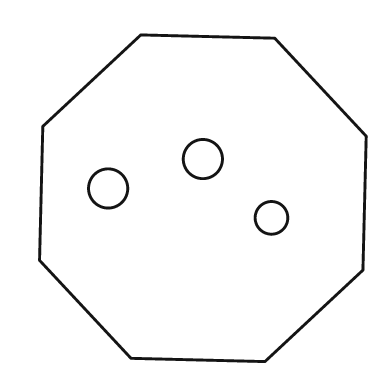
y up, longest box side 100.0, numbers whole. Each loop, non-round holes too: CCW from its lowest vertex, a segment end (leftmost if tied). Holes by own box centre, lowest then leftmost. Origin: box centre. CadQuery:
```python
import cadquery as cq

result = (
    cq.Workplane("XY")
    .moveTo(19.0, -50.0)
    .lineTo(49.0, -22.0)
    .lineTo(50.0, 19.0)
    .lineTo(22.0, 49.0)
    .lineTo(-19.0, 50.0)
    .lineTo(-49.0, 22.0)
    .lineTo(-50.0, -19.0)
    .lineTo(-22.0, -49.0)
    .close()
    .moveTo(21.0, -6.0)
    .circle(5.0)
    .moveTo(-29.0, 3.0)
    .circle(6.0)
    .moveTo(0.0, 12.0)
    .circle(6.0)
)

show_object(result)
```